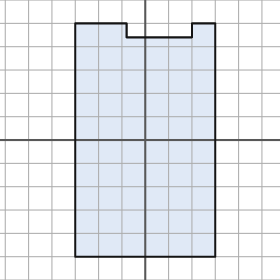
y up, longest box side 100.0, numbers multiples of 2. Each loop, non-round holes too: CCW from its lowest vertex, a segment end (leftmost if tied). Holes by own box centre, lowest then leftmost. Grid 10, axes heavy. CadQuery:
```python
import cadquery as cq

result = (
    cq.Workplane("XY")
    .moveTo(-30.0, -50.0)
    .lineTo(30.0, -50.0)
    .lineTo(30.0, 50.0)
    .lineTo(20.0, 50.0)
    .lineTo(20.0, 44.0)
    .lineTo(-8.0, 44.0)
    .lineTo(-8.0, 50.0)
    .lineTo(-30.0, 50.0)
    .close()
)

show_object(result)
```